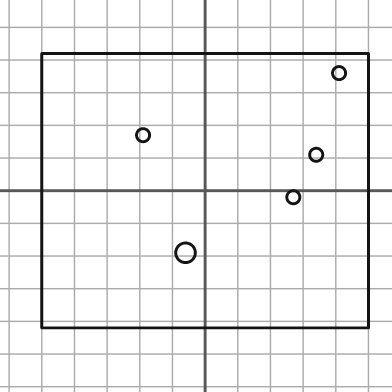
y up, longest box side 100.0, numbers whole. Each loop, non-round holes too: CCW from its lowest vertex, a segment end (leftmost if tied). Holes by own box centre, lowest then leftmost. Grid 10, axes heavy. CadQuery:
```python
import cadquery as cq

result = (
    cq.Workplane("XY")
    .moveTo(-50.0, -42.0)
    .lineTo(50.0, -42.0)
    .lineTo(50.0, 42.0)
    .lineTo(-50.0, 42.0)
    .close()
    .moveTo(-6.0, -19.0)
    .circle(3.0)
    .moveTo(27.0, -2.0)
    .circle(2.0)
    .moveTo(34.0, 11.0)
    .circle(2.0)
    .moveTo(-19.0, 17.0)
    .circle(2.0)
    .moveTo(41.0, 36.0)
    .circle(2.0)
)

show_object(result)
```